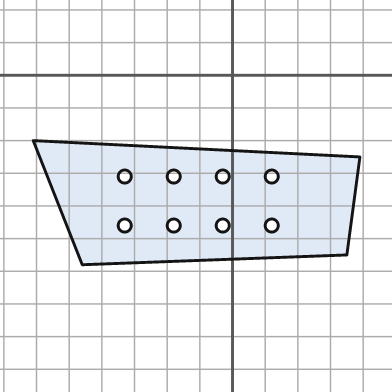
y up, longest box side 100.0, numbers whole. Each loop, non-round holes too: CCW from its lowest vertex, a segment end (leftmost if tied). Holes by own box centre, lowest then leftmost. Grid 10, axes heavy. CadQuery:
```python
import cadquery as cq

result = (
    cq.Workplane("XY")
    .moveTo(-46.0, -58.0)
    .lineTo(35.0, -55.0)
    .lineTo(39.0, -25.0)
    .lineTo(-61.0, -20.0)
    .close()
    .moveTo(-33.0, -46.0)
    .circle(2.0)
    .moveTo(-18.0, -46.0)
    .circle(2.0)
    .moveTo(-3.0, -46.0)
    .circle(2.0)
    .moveTo(12.0, -46.0)
    .circle(2.0)
    .moveTo(-33.0, -31.0)
    .circle(2.0)
    .moveTo(-18.0, -31.0)
    .circle(2.0)
    .moveTo(-3.0, -31.0)
    .circle(2.0)
    .moveTo(12.0, -31.0)
    .circle(2.0)
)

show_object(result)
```